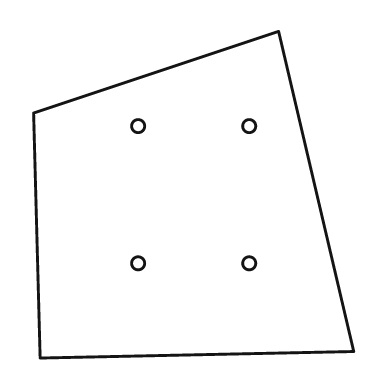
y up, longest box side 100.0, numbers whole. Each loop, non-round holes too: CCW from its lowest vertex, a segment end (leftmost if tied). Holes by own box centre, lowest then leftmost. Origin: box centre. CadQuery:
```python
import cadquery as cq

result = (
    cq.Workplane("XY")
    .moveTo(-47.0, -50.0)
    .lineTo(49.0, -48.0)
    .lineTo(26.0, 50.0)
    .lineTo(-49.0, 25.0)
    .close()
    .moveTo(-17.0, -21.0)
    .circle(2.0)
    .moveTo(17.0, -21.0)
    .circle(2.0)
    .moveTo(-17.0, 21.0)
    .circle(2.0)
    .moveTo(17.0, 21.0)
    .circle(2.0)
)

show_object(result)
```